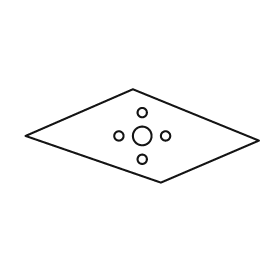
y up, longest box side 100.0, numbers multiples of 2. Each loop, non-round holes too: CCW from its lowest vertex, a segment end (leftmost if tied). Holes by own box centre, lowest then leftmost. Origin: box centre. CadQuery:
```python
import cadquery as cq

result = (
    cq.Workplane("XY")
    .moveTo(8.0, -20.0)
    .lineTo(50.0, -2.0)
    .lineTo(-4.0, 20.0)
    .lineTo(-50.0, 0.0)
    .close()
    .moveTo(0.0, -10.0)
    .circle(2.0)
    .moveTo(-10.0, 0.0)
    .circle(2.0)
    .moveTo(0.0, 0.0)
    .circle(4.0)
    .moveTo(10.0, 0.0)
    .circle(2.0)
    .moveTo(0.0, 10.0)
    .circle(2.0)
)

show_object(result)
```